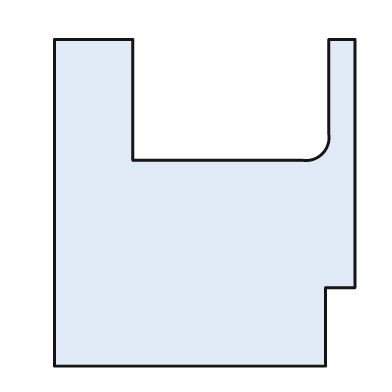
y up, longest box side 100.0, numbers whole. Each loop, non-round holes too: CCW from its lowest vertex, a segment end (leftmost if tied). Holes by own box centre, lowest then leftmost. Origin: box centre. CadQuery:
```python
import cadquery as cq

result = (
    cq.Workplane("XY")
    .moveTo(-46.0, -50.0)
    .lineTo(37.0, -50.0)
    .lineTo(37.0, -26.0)
    .lineTo(46.0, -26.0)
    .lineTo(46.0, 50.0)
    .lineTo(38.0, 50.0)
    .lineTo(38.0, 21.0)
    .threePointArc((36.0, 15.0), (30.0, 13.0))
    .lineTo(-22.0, 13.0)
    .lineTo(-22.0, 50.0)
    .lineTo(-46.0, 50.0)
    .close()
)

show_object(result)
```